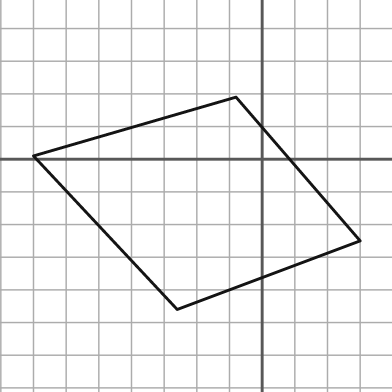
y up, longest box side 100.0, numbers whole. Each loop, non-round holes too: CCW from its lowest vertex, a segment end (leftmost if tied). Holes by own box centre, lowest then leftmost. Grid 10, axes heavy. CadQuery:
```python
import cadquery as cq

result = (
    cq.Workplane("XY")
    .moveTo(-26.0, -46.0)
    .lineTo(30.0, -25.0)
    .lineTo(-8.0, 19.0)
    .lineTo(-70.0, 1.0)
    .close()
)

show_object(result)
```